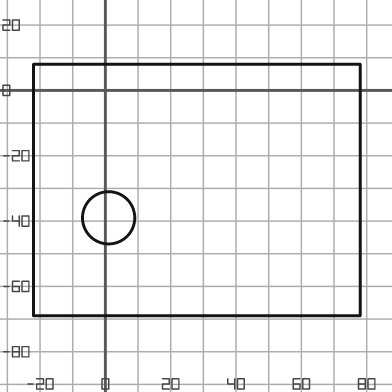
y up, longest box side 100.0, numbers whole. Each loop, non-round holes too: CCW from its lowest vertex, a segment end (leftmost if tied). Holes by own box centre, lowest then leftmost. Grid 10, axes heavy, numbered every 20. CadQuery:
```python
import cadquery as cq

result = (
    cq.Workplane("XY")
    .moveTo(-22.0, -69.0)
    .lineTo(78.0, -69.0)
    .lineTo(78.0, 8.0)
    .lineTo(-22.0, 8.0)
    .close()
    .moveTo(1.0, -39.0)
    .circle(8.0)
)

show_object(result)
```